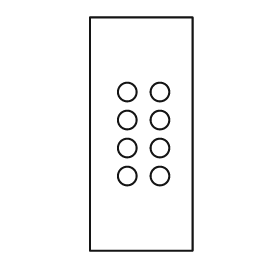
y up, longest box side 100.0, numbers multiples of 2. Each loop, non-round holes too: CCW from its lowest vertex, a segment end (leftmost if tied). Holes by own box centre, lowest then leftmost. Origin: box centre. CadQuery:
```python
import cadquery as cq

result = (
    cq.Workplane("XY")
    .moveTo(-22.0, -50.0)
    .lineTo(22.0, -50.0)
    .lineTo(22.0, 50.0)
    .lineTo(-22.0, 50.0)
    .close()
    .moveTo(-6.0, -18.0)
    .circle(4.0)
    .moveTo(8.0, -18.0)
    .circle(4.0)
    .moveTo(-6.0, -6.0)
    .circle(4.0)
    .moveTo(8.0, -6.0)
    .circle(4.0)
    .moveTo(-6.0, 6.0)
    .circle(4.0)
    .moveTo(8.0, 6.0)
    .circle(4.0)
    .moveTo(-6.0, 18.0)
    .circle(4.0)
    .moveTo(8.0, 18.0)
    .circle(4.0)
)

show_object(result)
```